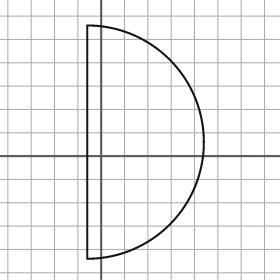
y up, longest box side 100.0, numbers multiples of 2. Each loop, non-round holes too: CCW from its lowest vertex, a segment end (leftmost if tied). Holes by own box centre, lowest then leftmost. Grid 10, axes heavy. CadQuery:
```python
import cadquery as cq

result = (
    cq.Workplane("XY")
    .moveTo(-6.0, -44.0)
    .threePointArc((44.0, 6.0), (-6.0, 56.0))
    .close()
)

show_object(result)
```